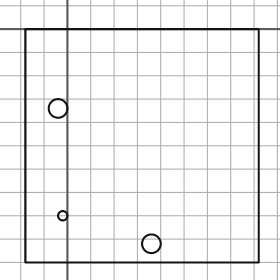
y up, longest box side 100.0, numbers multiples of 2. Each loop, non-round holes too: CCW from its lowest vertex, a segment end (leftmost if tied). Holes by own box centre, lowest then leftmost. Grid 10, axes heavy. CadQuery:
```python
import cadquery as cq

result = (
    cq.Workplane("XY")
    .moveTo(-18.0, -100.0)
    .lineTo(82.0, -100.0)
    .lineTo(82.0, 0.0)
    .lineTo(-18.0, 0.0)
    .close()
    .moveTo(36.0, -92.0)
    .circle(4.0)
    .moveTo(-2.0, -80.0)
    .circle(2.0)
    .moveTo(-4.0, -34.0)
    .circle(4.0)
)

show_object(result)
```